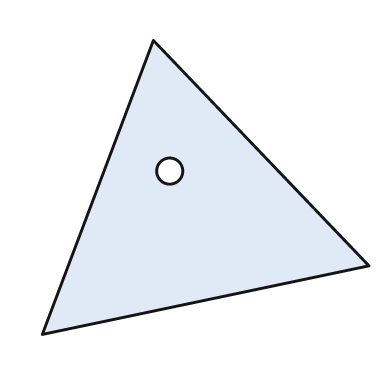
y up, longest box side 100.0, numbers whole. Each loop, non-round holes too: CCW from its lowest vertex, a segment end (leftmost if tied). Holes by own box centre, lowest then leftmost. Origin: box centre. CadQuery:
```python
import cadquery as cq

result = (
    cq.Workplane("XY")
    .moveTo(-50.0, -45.0)
    .lineTo(50.0, -24.0)
    .lineTo(-16.0, 45.0)
    .close()
    .moveTo(-11.0, 5.0)
    .circle(4.0)
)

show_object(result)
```